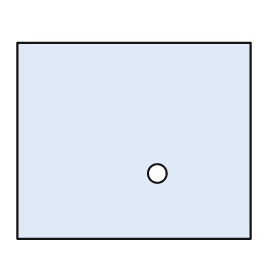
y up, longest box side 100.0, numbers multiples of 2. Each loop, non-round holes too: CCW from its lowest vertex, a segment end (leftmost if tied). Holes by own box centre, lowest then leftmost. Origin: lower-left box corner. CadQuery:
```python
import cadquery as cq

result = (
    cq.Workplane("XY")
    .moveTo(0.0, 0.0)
    .lineTo(100.0, 0.0)
    .lineTo(100.0, 84.0)
    .lineTo(0.0, 84.0)
    .close()
    .moveTo(60.0, 28.0)
    .circle(4.0)
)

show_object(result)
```